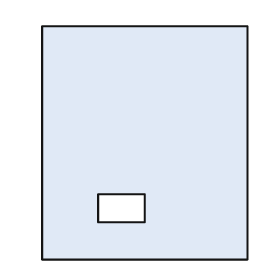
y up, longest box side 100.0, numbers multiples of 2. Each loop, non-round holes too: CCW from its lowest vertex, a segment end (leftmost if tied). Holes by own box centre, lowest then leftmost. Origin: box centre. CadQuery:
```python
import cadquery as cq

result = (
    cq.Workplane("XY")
    .moveTo(-44.0, -50.0)
    .lineTo(44.0, -50.0)
    .lineTo(44.0, 50.0)
    .lineTo(-44.0, 50.0)
    .close()
    .moveTo(-20.0, -34.0)
    .lineTo(0.0, -34.0)
    .lineTo(0.0, -22.0)
    .lineTo(-20.0, -22.0)
    .close()
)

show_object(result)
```